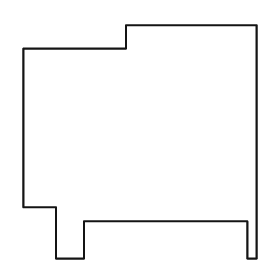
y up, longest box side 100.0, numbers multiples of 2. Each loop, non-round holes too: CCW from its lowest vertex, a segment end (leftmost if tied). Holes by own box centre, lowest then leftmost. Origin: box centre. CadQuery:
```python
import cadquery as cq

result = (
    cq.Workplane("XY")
    .moveTo(-36.0, -50.0)
    .lineTo(-24.0, -50.0)
    .lineTo(-24.0, -34.0)
    .lineTo(46.0, -34.0)
    .lineTo(46.0, -50.0)
    .lineTo(50.0, -50.0)
    .lineTo(50.0, 50.0)
    .lineTo(-6.0, 50.0)
    .lineTo(-6.0, 40.0)
    .lineTo(-50.0, 40.0)
    .lineTo(-50.0, -28.0)
    .lineTo(-36.0, -28.0)
    .close()
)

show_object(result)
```